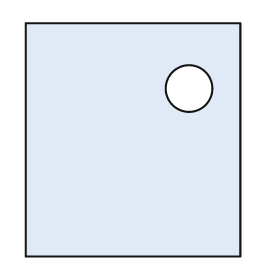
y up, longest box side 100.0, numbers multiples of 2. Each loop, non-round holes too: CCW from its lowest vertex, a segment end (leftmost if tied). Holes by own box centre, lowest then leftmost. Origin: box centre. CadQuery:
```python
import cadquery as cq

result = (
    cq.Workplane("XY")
    .moveTo(-46.0, -50.0)
    .lineTo(46.0, -50.0)
    .lineTo(46.0, 50.0)
    .lineTo(-46.0, 50.0)
    .close()
    .moveTo(24.0, 22.0)
    .circle(10.0)
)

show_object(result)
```